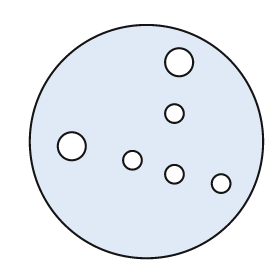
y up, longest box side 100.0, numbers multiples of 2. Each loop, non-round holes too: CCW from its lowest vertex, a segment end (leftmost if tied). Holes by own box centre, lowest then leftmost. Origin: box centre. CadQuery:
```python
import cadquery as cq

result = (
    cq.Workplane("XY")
    .moveTo(0.0, 0.0)
    .circle(50.0)
    .moveTo(32.0, -18.0)
    .circle(4.0)
    .moveTo(12.0, -14.0)
    .circle(4.0)
    .moveTo(-6.0, -8.0)
    .circle(4.0)
    .moveTo(-32.0, -2.0)
    .circle(6.0)
    .moveTo(12.0, 12.0)
    .circle(4.0)
    .moveTo(14.0, 34.0)
    .circle(6.0)
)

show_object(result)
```